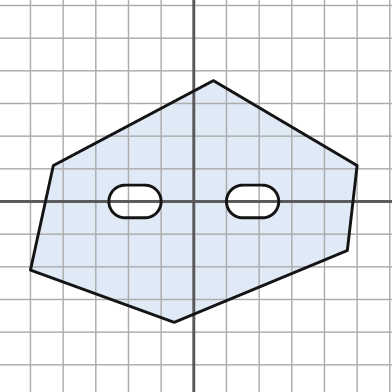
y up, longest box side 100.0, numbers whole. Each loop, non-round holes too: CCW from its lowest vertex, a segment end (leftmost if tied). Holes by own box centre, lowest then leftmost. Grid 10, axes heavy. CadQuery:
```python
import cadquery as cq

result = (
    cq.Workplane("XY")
    .moveTo(-6.0, -37.0)
    .lineTo(47.0, -15.0)
    .lineTo(50.0, 11.0)
    .lineTo(6.0, 37.0)
    .lineTo(-43.0, 11.0)
    .lineTo(-50.0, -21.0)
    .close()
    .moveTo(-21.0, -5.0)
    .lineTo(-15.0, -5.0)
    .threePointArc((-10.0, 0.0), (-15.0, 5.0))
    .lineTo(-21.0, 5.0)
    .threePointArc((-26.0, 0.0), (-21.0, -5.0))
    .close()
    .moveTo(15.0, -5.0)
    .lineTo(21.0, -5.0)
    .threePointArc((26.0, 0.0), (21.0, 5.0))
    .lineTo(15.0, 5.0)
    .threePointArc((10.0, 0.0), (15.0, -5.0))
    .close()
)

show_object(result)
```